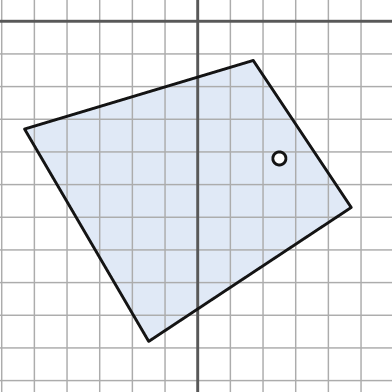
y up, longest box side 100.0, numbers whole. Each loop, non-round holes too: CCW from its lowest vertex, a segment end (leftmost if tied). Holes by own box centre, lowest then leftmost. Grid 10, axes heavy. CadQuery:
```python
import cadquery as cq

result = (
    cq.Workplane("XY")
    .moveTo(-15.0, -98.0)
    .lineTo(47.0, -57.0)
    .lineTo(17.0, -12.0)
    .lineTo(-53.0, -33.0)
    .close()
    .moveTo(25.0, -42.0)
    .circle(2.0)
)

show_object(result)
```